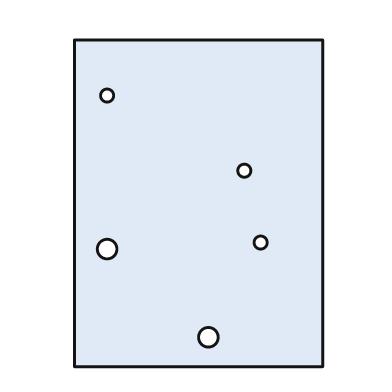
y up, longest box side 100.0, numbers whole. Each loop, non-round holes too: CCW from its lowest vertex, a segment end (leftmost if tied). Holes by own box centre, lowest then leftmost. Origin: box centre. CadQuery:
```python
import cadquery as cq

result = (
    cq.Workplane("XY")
    .moveTo(-38.0, -50.0)
    .lineTo(38.0, -50.0)
    .lineTo(38.0, 50.0)
    .lineTo(-38.0, 50.0)
    .close()
    .moveTo(3.0, -41.0)
    .circle(3.0)
    .moveTo(-28.0, -14.0)
    .circle(3.0)
    .moveTo(19.0, -12.0)
    .circle(2.0)
    .moveTo(14.0, 10.0)
    .circle(2.0)
    .moveTo(-28.0, 33.0)
    .circle(2.0)
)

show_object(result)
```